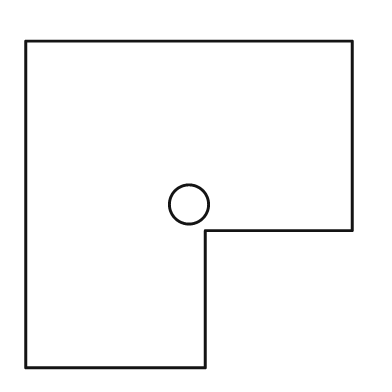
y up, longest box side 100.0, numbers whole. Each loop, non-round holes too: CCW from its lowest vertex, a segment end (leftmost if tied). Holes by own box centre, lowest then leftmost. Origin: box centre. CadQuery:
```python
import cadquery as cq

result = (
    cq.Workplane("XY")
    .moveTo(-50.0, -50.0)
    .lineTo(5.0, -50.0)
    .lineTo(5.0, -8.0)
    .lineTo(50.0, -8.0)
    .lineTo(50.0, 50.0)
    .lineTo(-50.0, 50.0)
    .close()
    .moveTo(0.0, 0.0)
    .circle(6.0)
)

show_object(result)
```